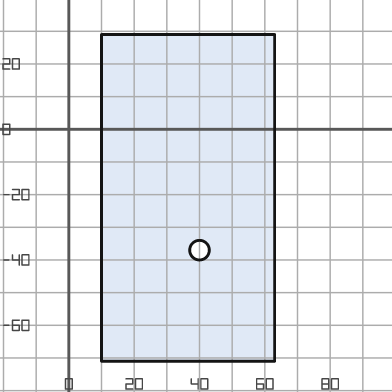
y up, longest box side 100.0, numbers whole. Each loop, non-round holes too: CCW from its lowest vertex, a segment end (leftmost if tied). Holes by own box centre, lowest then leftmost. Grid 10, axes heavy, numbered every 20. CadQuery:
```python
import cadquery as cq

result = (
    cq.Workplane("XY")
    .moveTo(10.0, -71.0)
    .lineTo(63.0, -71.0)
    .lineTo(63.0, 29.0)
    .lineTo(10.0, 29.0)
    .close()
    .moveTo(40.0, -37.0)
    .circle(3.0)
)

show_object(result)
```